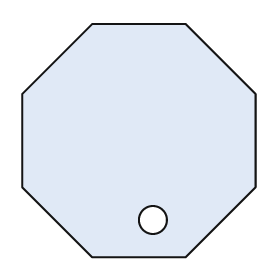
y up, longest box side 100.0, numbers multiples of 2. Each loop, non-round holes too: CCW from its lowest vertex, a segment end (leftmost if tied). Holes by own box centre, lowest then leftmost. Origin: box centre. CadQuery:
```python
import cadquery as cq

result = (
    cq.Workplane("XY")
    .moveTo(-20.0, -50.0)
    .lineTo(20.0, -50.0)
    .lineTo(50.0, -20.0)
    .lineTo(50.0, 20.0)
    .lineTo(20.0, 50.0)
    .lineTo(-20.0, 50.0)
    .lineTo(-50.0, 20.0)
    .lineTo(-50.0, -20.0)
    .close()
    .moveTo(6.0, -34.0)
    .circle(6.0)
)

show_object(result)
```